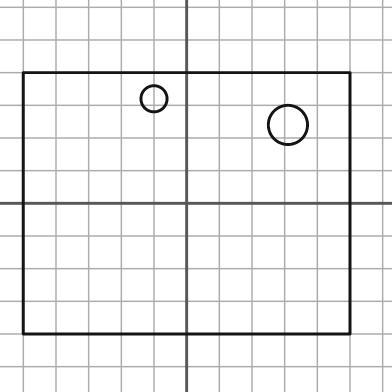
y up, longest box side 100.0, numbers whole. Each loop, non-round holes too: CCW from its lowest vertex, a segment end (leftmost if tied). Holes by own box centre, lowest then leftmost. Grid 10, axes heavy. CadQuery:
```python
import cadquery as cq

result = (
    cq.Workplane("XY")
    .moveTo(-50.0, -40.0)
    .lineTo(50.0, -40.0)
    .lineTo(50.0, 40.0)
    .lineTo(-50.0, 40.0)
    .close()
    .moveTo(31.0, 24.0)
    .circle(6.0)
    .moveTo(-10.0, 32.0)
    .circle(4.0)
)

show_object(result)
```